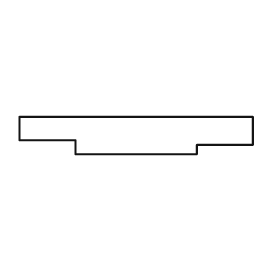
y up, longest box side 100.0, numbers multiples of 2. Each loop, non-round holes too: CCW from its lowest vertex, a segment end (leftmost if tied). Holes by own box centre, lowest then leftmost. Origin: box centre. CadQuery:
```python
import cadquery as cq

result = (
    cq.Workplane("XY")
    .moveTo(-26.0, -8.0)
    .lineTo(26.0, -8.0)
    .lineTo(26.0, -4.0)
    .lineTo(50.0, -4.0)
    .lineTo(50.0, 8.0)
    .lineTo(-50.0, 8.0)
    .lineTo(-50.0, -2.0)
    .lineTo(-26.0, -2.0)
    .close()
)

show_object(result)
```